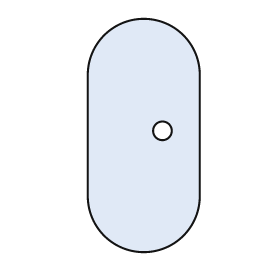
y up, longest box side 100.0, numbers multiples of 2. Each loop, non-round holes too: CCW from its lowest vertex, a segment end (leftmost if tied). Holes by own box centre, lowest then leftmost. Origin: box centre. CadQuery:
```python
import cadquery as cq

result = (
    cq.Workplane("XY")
    .moveTo(-24.0, -26.0)
    .threePointArc((0.0, -50.0), (24.0, -26.0))
    .lineTo(24.0, 26.0)
    .threePointArc((0.0, 50.0), (-24.0, 26.0))
    .close()
    .moveTo(8.0, 2.0)
    .circle(4.0)
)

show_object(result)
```